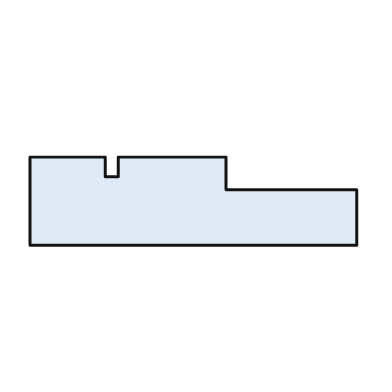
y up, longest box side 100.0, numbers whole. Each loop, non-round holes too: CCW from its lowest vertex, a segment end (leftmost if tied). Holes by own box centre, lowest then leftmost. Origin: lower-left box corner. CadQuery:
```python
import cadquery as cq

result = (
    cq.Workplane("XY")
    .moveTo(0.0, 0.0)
    .lineTo(100.0, 0.0)
    .lineTo(100.0, 17.0)
    .lineTo(60.0, 17.0)
    .lineTo(60.0, 27.0)
    .lineTo(27.0, 27.0)
    .lineTo(27.0, 21.0)
    .lineTo(23.0, 21.0)
    .lineTo(23.0, 27.0)
    .lineTo(0.0, 27.0)
    .close()
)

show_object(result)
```